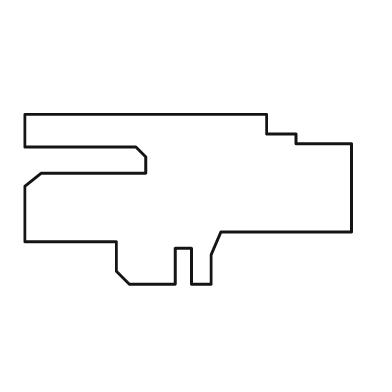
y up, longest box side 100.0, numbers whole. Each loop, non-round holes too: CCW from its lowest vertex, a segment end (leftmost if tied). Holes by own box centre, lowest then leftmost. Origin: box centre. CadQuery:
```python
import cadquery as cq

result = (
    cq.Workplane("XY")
    .moveTo(-18.0, -26.0)
    .lineTo(-4.0, -26.0)
    .lineTo(-4.0, -15.0)
    .lineTo(1.0, -15.0)
    .lineTo(1.0, -26.0)
    .lineTo(7.0, -26.0)
    .lineTo(7.0, -17.0)
    .lineTo(10.0, -10.0)
    .lineTo(50.0, -10.0)
    .lineTo(50.0, 17.0)
    .lineTo(33.0, 17.0)
    .lineTo(33.0, 20.0)
    .lineTo(24.0, 20.0)
    .lineTo(24.0, 26.0)
    .lineTo(-50.0, 26.0)
    .lineTo(-50.0, 16.0)
    .lineTo(-16.0, 16.0)
    .lineTo(-13.0, 13.0)
    .lineTo(-13.0, 8.0)
    .lineTo(-45.0, 8.0)
    .lineTo(-50.0, 4.0)
    .lineTo(-50.0, -13.0)
    .lineTo(-22.0, -13.0)
    .lineTo(-22.0, -22.0)
    .close()
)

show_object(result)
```